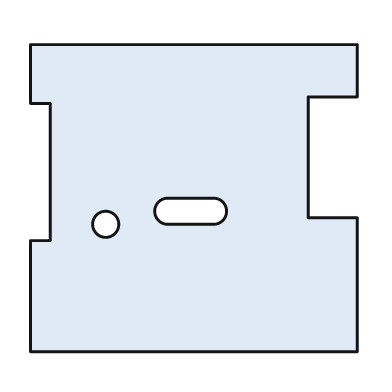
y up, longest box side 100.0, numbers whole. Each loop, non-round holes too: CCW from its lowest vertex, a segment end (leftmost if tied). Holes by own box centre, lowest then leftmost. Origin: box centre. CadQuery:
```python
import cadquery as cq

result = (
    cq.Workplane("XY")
    .moveTo(-50.0, -47.0)
    .lineTo(50.0, -47.0)
    .lineTo(50.0, -6.0)
    .lineTo(35.0, -6.0)
    .lineTo(35.0, 31.0)
    .lineTo(50.0, 31.0)
    .lineTo(50.0, 47.0)
    .lineTo(-50.0, 47.0)
    .lineTo(-50.0, 29.0)
    .lineTo(-44.0, 29.0)
    .lineTo(-44.0, -13.0)
    .lineTo(-50.0, -13.0)
    .close()
    .moveTo(-27.0, -8.0)
    .circle(4.0)
    .moveTo(-8.0, -8.0)
    .lineTo(6.0, -8.0)
    .threePointArc((10.0, -4.0), (6.0, 0.0))
    .lineTo(-8.0, 0.0)
    .threePointArc((-12.0, -4.0), (-8.0, -8.0))
    .close()
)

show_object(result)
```